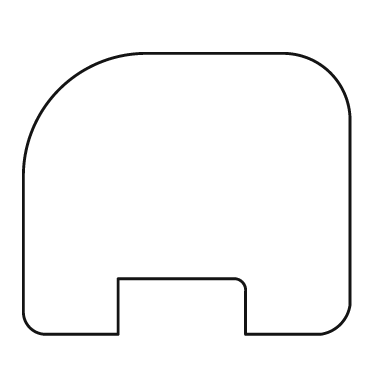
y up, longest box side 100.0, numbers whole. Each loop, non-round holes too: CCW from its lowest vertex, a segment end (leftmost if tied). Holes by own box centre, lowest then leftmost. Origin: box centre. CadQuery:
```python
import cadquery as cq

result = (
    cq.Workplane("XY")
    .moveTo(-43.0, -43.0)
    .lineTo(-21.0, -43.0)
    .lineTo(-21.0, -26.0)
    .lineTo(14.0, -26.0)
    .threePointArc((17.0, -27.0), (18.0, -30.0))
    .lineTo(18.0, -43.0)
    .lineTo(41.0, -43.0)
    .threePointArc((47.0, -40.0), (50.0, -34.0))
    .lineTo(50.0, 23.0)
    .threePointArc((44.0, 37.0), (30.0, 43.0))
    .lineTo(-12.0, 43.0)
    .threePointArc((-39.0, 32.0), (-50.0, 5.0))
    .lineTo(-50.0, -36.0)
    .threePointArc((-48.0, -41.0), (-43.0, -43.0))
    .close()
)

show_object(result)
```